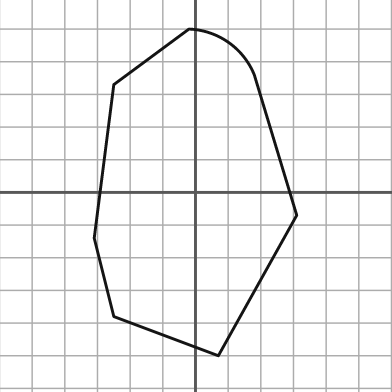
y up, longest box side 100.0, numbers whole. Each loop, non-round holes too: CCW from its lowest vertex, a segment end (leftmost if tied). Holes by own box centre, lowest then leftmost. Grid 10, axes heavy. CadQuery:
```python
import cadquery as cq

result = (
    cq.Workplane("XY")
    .moveTo(7.0, -50.0)
    .lineTo(31.0, -7.0)
    .lineTo(18.0, 36.0)
    .threePointArc((10.0, 46.0), (-2.0, 50.0))
    .lineTo(-25.0, 33.0)
    .lineTo(-31.0, -14.0)
    .lineTo(-25.0, -38.0)
    .close()
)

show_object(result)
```